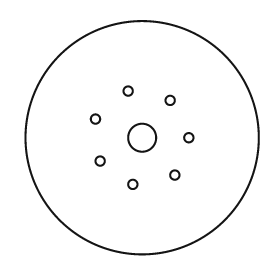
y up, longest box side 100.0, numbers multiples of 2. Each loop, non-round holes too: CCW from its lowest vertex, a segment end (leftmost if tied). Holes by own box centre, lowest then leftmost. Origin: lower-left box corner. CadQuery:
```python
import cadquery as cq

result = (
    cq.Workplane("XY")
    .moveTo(50.0, 50.0)
    .circle(50.0)
    .moveTo(46.0, 30.0)
    .circle(2.0)
    .moveTo(64.0, 34.0)
    .circle(2.0)
    .moveTo(32.0, 40.0)
    .circle(2.0)
    .moveTo(50.0, 50.0)
    .circle(6.0)
    .moveTo(70.0, 50.0)
    .circle(2.0)
    .moveTo(30.0, 58.0)
    .circle(2.0)
    .moveTo(62.0, 66.0)
    .circle(2.0)
    .moveTo(44.0, 70.0)
    .circle(2.0)
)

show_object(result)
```